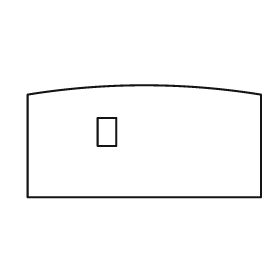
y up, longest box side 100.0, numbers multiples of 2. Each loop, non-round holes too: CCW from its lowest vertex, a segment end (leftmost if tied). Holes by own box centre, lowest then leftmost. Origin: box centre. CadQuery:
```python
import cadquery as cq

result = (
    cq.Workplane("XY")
    .moveTo(-50.0, -24.0)
    .lineTo(50.0, -24.0)
    .lineTo(50.0, 20.0)
    .threePointArc((0.0, 24.0), (-50.0, 20.0))
    .close()
    .moveTo(-20.0, -2.0)
    .lineTo(-12.0, -2.0)
    .lineTo(-12.0, 10.0)
    .lineTo(-20.0, 10.0)
    .close()
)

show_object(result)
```